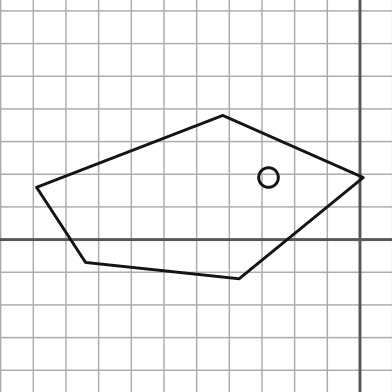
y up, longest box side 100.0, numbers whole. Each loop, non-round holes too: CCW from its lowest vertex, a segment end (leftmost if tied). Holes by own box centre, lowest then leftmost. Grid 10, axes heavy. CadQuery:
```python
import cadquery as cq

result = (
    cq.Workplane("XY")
    .moveTo(-37.0, -12.0)
    .lineTo(1.0, 19.0)
    .lineTo(-42.0, 38.0)
    .lineTo(-99.0, 16.0)
    .lineTo(-84.0, -7.0)
    .close()
    .moveTo(-28.0, 19.0)
    .circle(3.0)
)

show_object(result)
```